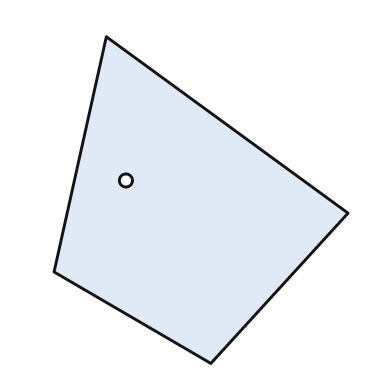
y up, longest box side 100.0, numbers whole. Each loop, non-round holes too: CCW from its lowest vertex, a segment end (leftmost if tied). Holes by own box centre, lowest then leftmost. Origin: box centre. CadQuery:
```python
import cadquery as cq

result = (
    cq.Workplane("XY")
    .moveTo(3.0, -50.0)
    .lineTo(45.0, -4.0)
    .lineTo(-29.0, 50.0)
    .lineTo(-45.0, -22.0)
    .close()
    .moveTo(-23.0, 6.0)
    .circle(2.0)
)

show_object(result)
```